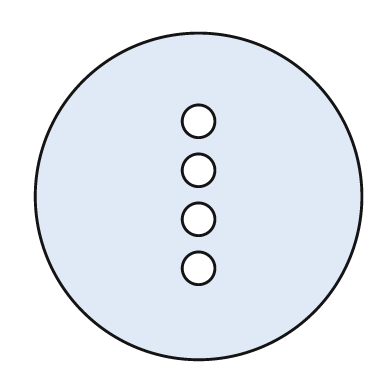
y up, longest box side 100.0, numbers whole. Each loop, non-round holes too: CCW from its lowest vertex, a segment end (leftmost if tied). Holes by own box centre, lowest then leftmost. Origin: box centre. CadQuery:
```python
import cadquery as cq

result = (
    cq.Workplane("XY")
    .moveTo(0.0, 0.0)
    .circle(50.0)
    .moveTo(0.0, -22.0)
    .circle(5.0)
    .moveTo(0.0, -7.0)
    .circle(5.0)
    .moveTo(0.0, 8.0)
    .circle(5.0)
    .moveTo(0.0, 23.0)
    .circle(5.0)
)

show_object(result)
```